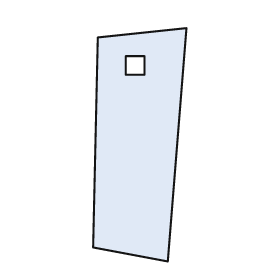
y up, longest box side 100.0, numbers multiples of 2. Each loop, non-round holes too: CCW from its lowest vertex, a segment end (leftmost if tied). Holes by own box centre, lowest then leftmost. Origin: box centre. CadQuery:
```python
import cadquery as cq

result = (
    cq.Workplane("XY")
    .moveTo(12.0, -50.0)
    .lineTo(20.0, 50.0)
    .lineTo(-18.0, 46.0)
    .lineTo(-20.0, -44.0)
    .close()
    .moveTo(-6.0, 30.0)
    .lineTo(2.0, 30.0)
    .lineTo(2.0, 38.0)
    .lineTo(-6.0, 38.0)
    .close()
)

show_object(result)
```